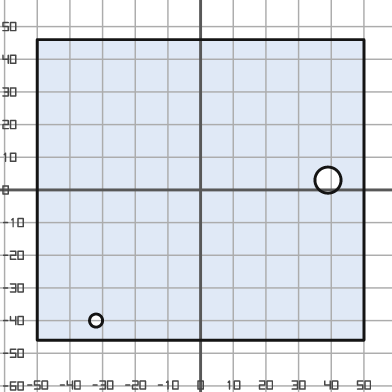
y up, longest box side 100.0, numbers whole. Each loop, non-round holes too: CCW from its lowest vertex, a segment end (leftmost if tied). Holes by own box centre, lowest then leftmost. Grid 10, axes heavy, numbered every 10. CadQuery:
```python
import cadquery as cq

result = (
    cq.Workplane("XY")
    .moveTo(-50.0, -46.0)
    .lineTo(50.0, -46.0)
    .lineTo(50.0, 46.0)
    .lineTo(-50.0, 46.0)
    .close()
    .moveTo(-32.0, -40.0)
    .circle(2.0)
    .moveTo(39.0, 3.0)
    .circle(4.0)
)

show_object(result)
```